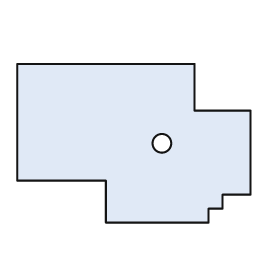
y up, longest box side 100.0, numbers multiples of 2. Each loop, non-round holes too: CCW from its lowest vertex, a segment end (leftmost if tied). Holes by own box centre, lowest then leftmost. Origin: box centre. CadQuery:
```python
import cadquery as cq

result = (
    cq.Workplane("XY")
    .moveTo(-12.0, -34.0)
    .lineTo(32.0, -34.0)
    .lineTo(32.0, -28.0)
    .lineTo(38.0, -28.0)
    .lineTo(38.0, -22.0)
    .lineTo(50.0, -22.0)
    .lineTo(50.0, 14.0)
    .lineTo(26.0, 14.0)
    .lineTo(26.0, 34.0)
    .lineTo(-50.0, 34.0)
    .lineTo(-50.0, -16.0)
    .lineTo(-12.0, -16.0)
    .close()
    .moveTo(12.0, 0.0)
    .circle(4.0)
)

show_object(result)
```